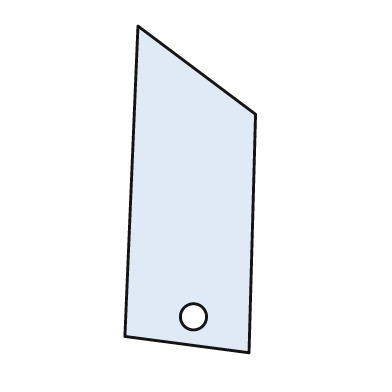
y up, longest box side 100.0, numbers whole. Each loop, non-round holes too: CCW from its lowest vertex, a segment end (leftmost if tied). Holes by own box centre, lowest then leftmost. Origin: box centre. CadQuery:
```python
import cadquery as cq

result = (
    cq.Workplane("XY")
    .moveTo(18.0, -50.0)
    .lineTo(20.0, 23.0)
    .lineTo(-16.0, 50.0)
    .lineTo(-20.0, -45.0)
    .close()
    .moveTo(1.0, -39.0)
    .circle(4.0)
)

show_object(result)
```